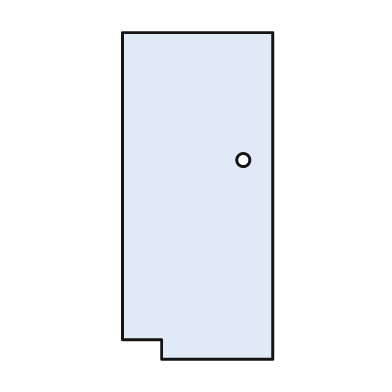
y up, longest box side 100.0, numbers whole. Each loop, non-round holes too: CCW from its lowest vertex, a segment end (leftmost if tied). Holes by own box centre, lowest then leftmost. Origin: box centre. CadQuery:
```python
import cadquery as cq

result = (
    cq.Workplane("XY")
    .moveTo(-11.0, -50.0)
    .lineTo(23.0, -50.0)
    .lineTo(23.0, 50.0)
    .lineTo(-23.0, 50.0)
    .lineTo(-23.0, -44.0)
    .lineTo(-11.0, -44.0)
    .close()
    .moveTo(14.0, 11.0)
    .circle(2.0)
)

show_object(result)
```